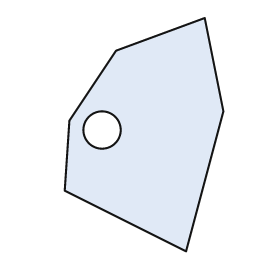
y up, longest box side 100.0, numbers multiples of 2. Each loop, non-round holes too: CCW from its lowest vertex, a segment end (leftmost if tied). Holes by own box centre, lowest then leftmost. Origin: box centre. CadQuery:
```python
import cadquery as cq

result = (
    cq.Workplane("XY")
    .moveTo(18.0, -50.0)
    .lineTo(34.0, 10.0)
    .lineTo(26.0, 50.0)
    .lineTo(-12.0, 36.0)
    .lineTo(-32.0, 6.0)
    .lineTo(-34.0, -24.0)
    .close()
    .moveTo(-18.0, 2.0)
    .circle(8.0)
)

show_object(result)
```